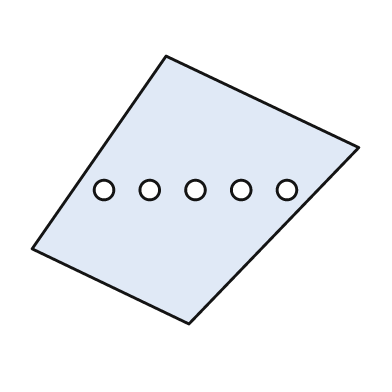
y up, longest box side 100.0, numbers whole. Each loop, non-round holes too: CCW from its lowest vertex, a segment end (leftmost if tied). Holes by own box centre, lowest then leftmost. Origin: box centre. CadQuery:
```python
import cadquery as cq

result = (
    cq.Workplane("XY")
    .moveTo(-2.0, -41.0)
    .lineTo(50.0, 13.0)
    .lineTo(-9.0, 41.0)
    .lineTo(-50.0, -18.0)
    .close()
    .moveTo(-28.0, 0.0)
    .circle(3.0)
    .moveTo(-14.0, 0.0)
    .circle(3.0)
    .moveTo(0.0, 0.0)
    .circle(3.0)
    .moveTo(14.0, 0.0)
    .circle(3.0)
    .moveTo(28.0, 0.0)
    .circle(3.0)
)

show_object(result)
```